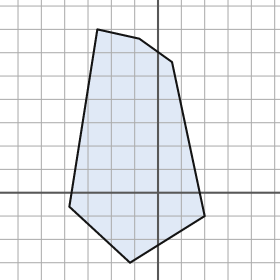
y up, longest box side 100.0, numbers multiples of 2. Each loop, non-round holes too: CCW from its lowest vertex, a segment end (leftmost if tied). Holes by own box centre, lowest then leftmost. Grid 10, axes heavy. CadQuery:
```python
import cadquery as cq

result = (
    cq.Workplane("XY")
    .moveTo(-12.0, -30.0)
    .lineTo(20.0, -10.0)
    .lineTo(6.0, 56.0)
    .lineTo(-8.0, 66.0)
    .lineTo(-26.0, 70.0)
    .lineTo(-38.0, -6.0)
    .close()
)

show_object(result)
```